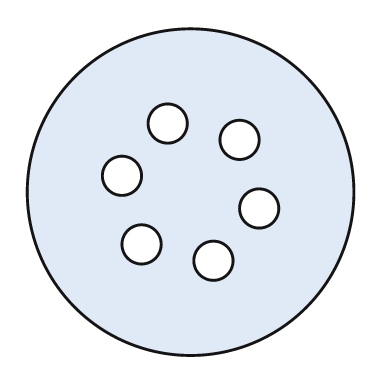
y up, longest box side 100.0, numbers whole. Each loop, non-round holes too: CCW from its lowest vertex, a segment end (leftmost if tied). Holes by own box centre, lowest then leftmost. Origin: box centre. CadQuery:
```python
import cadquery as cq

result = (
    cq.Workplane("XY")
    .moveTo(0.0, 0.0)
    .circle(50.0)
    .moveTo(7.0, -21.0)
    .circle(6.0)
    .moveTo(-15.0, -16.0)
    .circle(6.0)
    .moveTo(21.0, -5.0)
    .circle(6.0)
    .moveTo(-21.0, 5.0)
    .circle(6.0)
    .moveTo(15.0, 16.0)
    .circle(6.0)
    .moveTo(-7.0, 21.0)
    .circle(6.0)
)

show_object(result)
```